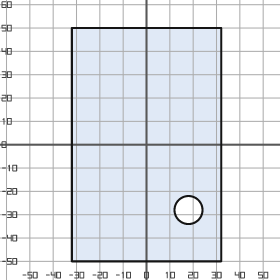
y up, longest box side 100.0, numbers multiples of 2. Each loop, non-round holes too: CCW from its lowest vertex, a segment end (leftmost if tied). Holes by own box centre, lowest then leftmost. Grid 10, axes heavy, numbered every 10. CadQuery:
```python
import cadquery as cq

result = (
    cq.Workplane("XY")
    .moveTo(-32.0, -50.0)
    .lineTo(32.0, -50.0)
    .lineTo(32.0, 50.0)
    .lineTo(-32.0, 50.0)
    .close()
    .moveTo(18.0, -28.0)
    .circle(6.0)
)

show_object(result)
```